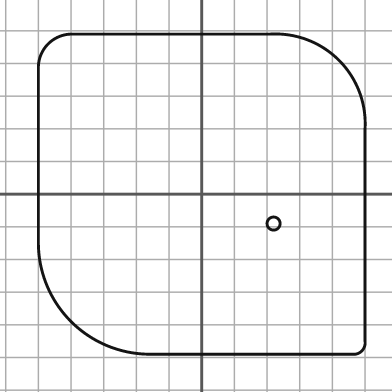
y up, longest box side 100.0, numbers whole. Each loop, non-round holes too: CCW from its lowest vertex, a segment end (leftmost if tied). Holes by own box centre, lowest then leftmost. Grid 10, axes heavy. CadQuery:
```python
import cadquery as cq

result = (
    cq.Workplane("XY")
    .moveTo(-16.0, -49.0)
    .lineTo(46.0, -49.0)
    .threePointArc((49.0, -48.0), (50.0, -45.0))
    .lineTo(50.0, 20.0)
    .threePointArc((42.0, 41.0), (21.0, 49.0))
    .lineTo(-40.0, 49.0)
    .threePointArc((-47.0, 46.0), (-50.0, 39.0))
    .lineTo(-50.0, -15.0)
    .threePointArc((-40.0, -39.0), (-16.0, -49.0))
    .close()
    .moveTo(22.0, -9.0)
    .circle(2.0)
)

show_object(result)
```